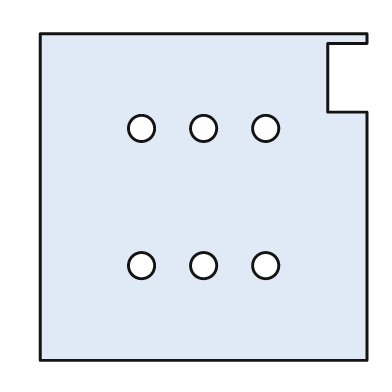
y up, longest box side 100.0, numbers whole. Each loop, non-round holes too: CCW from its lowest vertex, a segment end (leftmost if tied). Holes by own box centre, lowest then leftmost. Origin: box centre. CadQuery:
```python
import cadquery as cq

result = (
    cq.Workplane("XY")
    .moveTo(-50.0, -50.0)
    .lineTo(50.0, -50.0)
    .lineTo(50.0, 26.0)
    .lineTo(38.0, 26.0)
    .lineTo(38.0, 47.0)
    .lineTo(50.0, 47.0)
    .lineTo(50.0, 50.0)
    .lineTo(-50.0, 50.0)
    .close()
    .moveTo(-19.0, -21.0)
    .circle(4.0)
    .moveTo(0.0, -21.0)
    .circle(4.0)
    .moveTo(19.0, -21.0)
    .circle(4.0)
    .moveTo(-19.0, 21.0)
    .circle(4.0)
    .moveTo(0.0, 21.0)
    .circle(4.0)
    .moveTo(19.0, 21.0)
    .circle(4.0)
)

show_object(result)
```